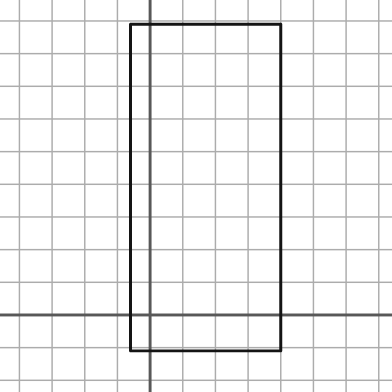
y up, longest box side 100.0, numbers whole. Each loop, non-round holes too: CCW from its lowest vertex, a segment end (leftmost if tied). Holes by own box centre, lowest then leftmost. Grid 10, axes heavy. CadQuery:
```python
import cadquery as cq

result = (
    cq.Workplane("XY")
    .moveTo(-6.0, -11.0)
    .lineTo(40.0, -11.0)
    .lineTo(40.0, 89.0)
    .lineTo(-6.0, 89.0)
    .close()
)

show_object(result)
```